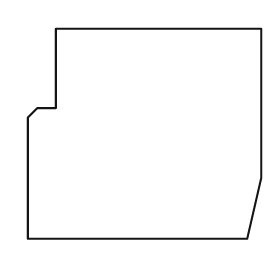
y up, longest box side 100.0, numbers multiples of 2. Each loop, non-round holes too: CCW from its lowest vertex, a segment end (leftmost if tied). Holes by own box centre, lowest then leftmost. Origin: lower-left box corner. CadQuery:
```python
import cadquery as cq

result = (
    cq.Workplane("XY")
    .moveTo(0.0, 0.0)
    .lineTo(94.0, 0.0)
    .lineTo(100.0, 26.0)
    .lineTo(100.0, 90.0)
    .lineTo(12.0, 90.0)
    .lineTo(12.0, 56.0)
    .lineTo(4.0, 56.0)
    .lineTo(0.0, 52.0)
    .close()
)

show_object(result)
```